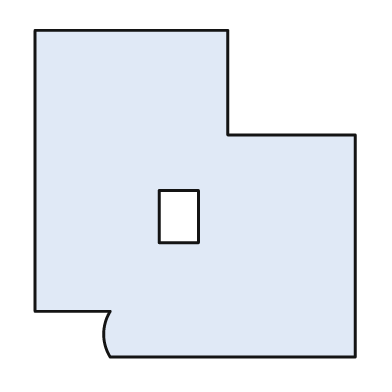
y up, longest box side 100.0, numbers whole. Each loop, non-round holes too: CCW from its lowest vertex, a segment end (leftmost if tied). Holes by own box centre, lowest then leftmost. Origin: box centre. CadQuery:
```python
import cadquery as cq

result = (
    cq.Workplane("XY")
    .moveTo(-26.0, -50.0)
    .lineTo(49.0, -50.0)
    .lineTo(49.0, 18.0)
    .lineTo(10.0, 18.0)
    .lineTo(10.0, 50.0)
    .lineTo(-49.0, 50.0)
    .lineTo(-49.0, -36.0)
    .lineTo(-26.0, -36.0)
    .threePointArc((-28.0, -43.0), (-26.0, -50.0))
    .close()
    .moveTo(-11.0, -15.0)
    .lineTo(1.0, -15.0)
    .lineTo(1.0, 1.0)
    .lineTo(-11.0, 1.0)
    .close()
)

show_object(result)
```